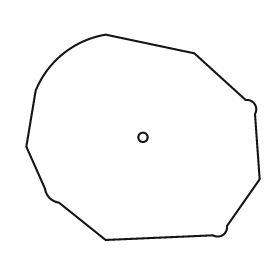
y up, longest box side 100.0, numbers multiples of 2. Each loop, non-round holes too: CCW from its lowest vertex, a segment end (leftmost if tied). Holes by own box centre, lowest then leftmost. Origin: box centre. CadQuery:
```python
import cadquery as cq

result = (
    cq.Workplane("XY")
    .moveTo(-16.0, -44.0)
    .lineTo(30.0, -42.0)
    .threePointArc((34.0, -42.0), (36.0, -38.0))
    .lineTo(50.0, -18.0)
    .lineTo(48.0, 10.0)
    .threePointArc((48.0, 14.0), (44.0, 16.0))
    .lineTo(22.0, 36.0)
    .lineTo(-16.0, 44.0)
    .threePointArc((-34.0, 36.0), (-46.0, 20.0))
    .lineTo(-50.0, -4.0)
    .lineTo(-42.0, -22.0)
    .threePointArc((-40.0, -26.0), (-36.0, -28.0))
    .close()
    .moveTo(0.0, 0.0)
    .circle(2.0)
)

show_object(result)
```